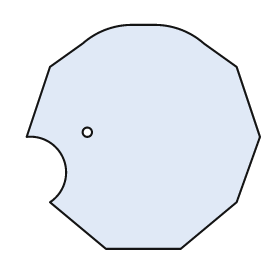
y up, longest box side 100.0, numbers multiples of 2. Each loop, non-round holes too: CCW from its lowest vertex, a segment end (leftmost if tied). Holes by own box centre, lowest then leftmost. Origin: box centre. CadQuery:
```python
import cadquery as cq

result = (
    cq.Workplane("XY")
    .moveTo(-16.0, -48.0)
    .lineTo(16.0, -48.0)
    .lineTo(40.0, -28.0)
    .lineTo(50.0, 0.0)
    .lineTo(40.0, 30.0)
    .lineTo(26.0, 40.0)
    .threePointArc((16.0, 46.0), (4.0, 48.0))
    .lineTo(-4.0, 48.0)
    .threePointArc((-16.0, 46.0), (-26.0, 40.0))
    .lineTo(-40.0, 30.0)
    .lineTo(-50.0, 0.0)
    .threePointArc((-34.0, -10.0), (-40.0, -28.0))
    .close()
    .moveTo(-24.0, 2.0)
    .circle(2.0)
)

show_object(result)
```